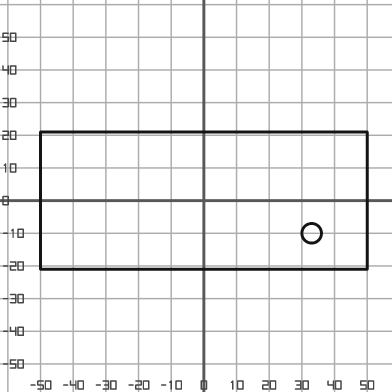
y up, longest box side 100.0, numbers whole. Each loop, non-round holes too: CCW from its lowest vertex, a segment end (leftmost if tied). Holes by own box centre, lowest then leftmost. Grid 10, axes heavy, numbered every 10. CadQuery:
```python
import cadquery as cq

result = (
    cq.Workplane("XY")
    .moveTo(-50.0, -21.0)
    .lineTo(50.0, -21.0)
    .lineTo(50.0, 21.0)
    .lineTo(-50.0, 21.0)
    .close()
    .moveTo(33.0, -10.0)
    .circle(3.0)
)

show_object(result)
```